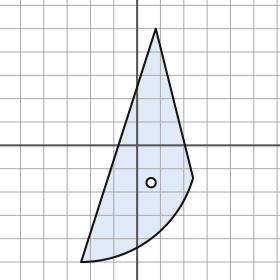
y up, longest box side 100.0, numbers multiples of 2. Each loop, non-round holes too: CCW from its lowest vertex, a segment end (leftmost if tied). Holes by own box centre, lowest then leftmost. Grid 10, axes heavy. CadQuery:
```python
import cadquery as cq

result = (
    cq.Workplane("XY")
    .moveTo(-24.0, -50.0)
    .threePointArc((6.0, -40.0), (24.0, -14.0))
    .lineTo(8.0, 50.0)
    .close()
    .moveTo(6.0, -16.0)
    .circle(2.0)
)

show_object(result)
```